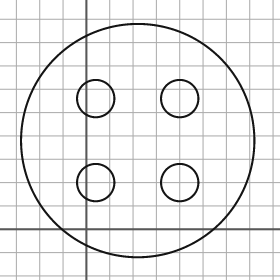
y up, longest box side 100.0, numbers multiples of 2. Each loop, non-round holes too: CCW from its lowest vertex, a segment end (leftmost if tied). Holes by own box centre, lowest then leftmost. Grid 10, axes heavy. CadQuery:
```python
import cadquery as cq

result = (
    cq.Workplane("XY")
    .moveTo(22.0, 38.0)
    .circle(50.0)
    .moveTo(4.0, 20.0)
    .circle(8.0)
    .moveTo(40.0, 20.0)
    .circle(8.0)
    .moveTo(4.0, 56.0)
    .circle(8.0)
    .moveTo(40.0, 56.0)
    .circle(8.0)
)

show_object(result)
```